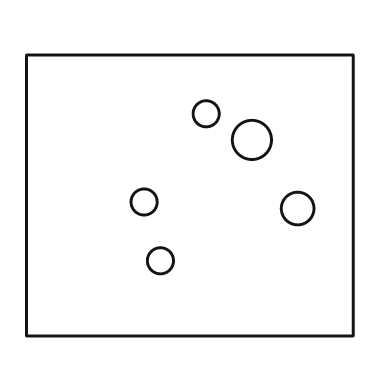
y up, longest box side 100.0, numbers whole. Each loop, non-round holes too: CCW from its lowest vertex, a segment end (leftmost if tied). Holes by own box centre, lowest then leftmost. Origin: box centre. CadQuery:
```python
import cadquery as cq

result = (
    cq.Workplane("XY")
    .moveTo(-50.0, -43.0)
    .lineTo(50.0, -43.0)
    .lineTo(50.0, 43.0)
    .lineTo(-50.0, 43.0)
    .close()
    .moveTo(-9.0, -20.0)
    .circle(4.0)
    .moveTo(33.0, -4.0)
    .circle(5.0)
    .moveTo(-14.0, -2.0)
    .circle(4.0)
    .moveTo(19.0, 17.0)
    .circle(6.0)
    .moveTo(5.0, 25.0)
    .circle(4.0)
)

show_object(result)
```